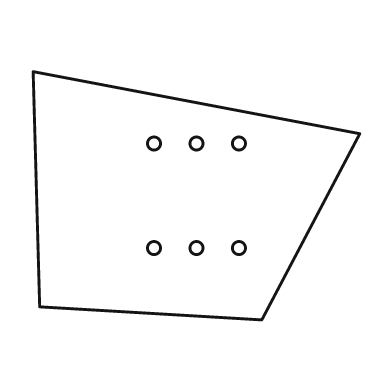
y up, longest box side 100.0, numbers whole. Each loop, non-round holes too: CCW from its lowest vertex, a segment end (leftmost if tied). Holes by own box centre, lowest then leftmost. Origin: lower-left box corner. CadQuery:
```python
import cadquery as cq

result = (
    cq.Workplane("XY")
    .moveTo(70.0, 0.0)
    .lineTo(100.0, 57.0)
    .lineTo(0.0, 76.0)
    .lineTo(2.0, 4.0)
    .close()
    .moveTo(37.0, 22.0)
    .circle(2.0)
    .moveTo(50.0, 22.0)
    .circle(2.0)
    .moveTo(63.0, 22.0)
    .circle(2.0)
    .moveTo(37.0, 54.0)
    .circle(2.0)
    .moveTo(50.0, 54.0)
    .circle(2.0)
    .moveTo(63.0, 54.0)
    .circle(2.0)
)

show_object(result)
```